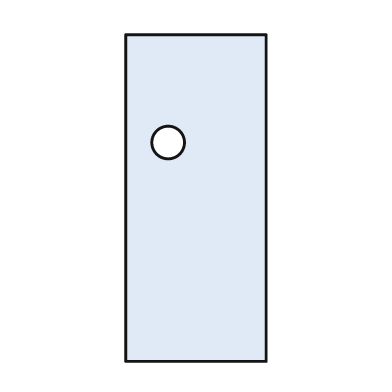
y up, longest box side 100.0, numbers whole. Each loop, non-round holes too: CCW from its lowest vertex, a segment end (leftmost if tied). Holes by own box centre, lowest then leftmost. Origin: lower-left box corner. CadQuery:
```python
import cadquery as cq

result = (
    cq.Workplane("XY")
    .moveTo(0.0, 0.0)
    .lineTo(43.0, 0.0)
    .lineTo(43.0, 100.0)
    .lineTo(0.0, 100.0)
    .close()
    .moveTo(13.0, 67.0)
    .circle(5.0)
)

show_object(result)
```